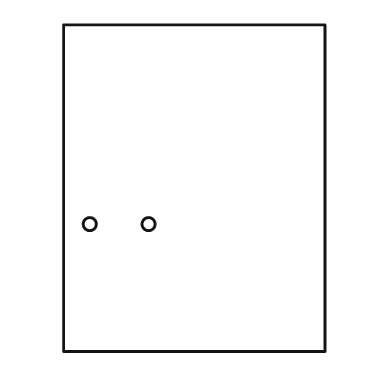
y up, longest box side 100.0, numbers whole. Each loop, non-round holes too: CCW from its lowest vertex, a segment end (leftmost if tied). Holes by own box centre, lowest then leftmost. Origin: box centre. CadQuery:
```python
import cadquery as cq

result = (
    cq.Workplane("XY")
    .moveTo(-40.0, -50.0)
    .lineTo(40.0, -50.0)
    .lineTo(40.0, 50.0)
    .lineTo(-40.0, 50.0)
    .close()
    .moveTo(-32.0, -11.0)
    .circle(2.0)
    .moveTo(-14.0, -11.0)
    .circle(2.0)
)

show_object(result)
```